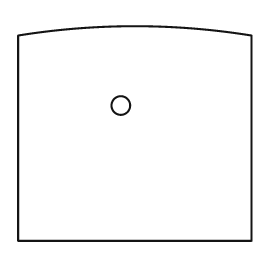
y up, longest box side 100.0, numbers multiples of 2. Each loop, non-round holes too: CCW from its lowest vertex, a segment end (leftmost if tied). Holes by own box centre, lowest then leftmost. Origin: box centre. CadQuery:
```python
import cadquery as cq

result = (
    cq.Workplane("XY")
    .moveTo(-50.0, -46.0)
    .lineTo(50.0, -46.0)
    .lineTo(50.0, 42.0)
    .threePointArc((0.0, 46.0), (-50.0, 42.0))
    .close()
    .moveTo(-6.0, 12.0)
    .circle(4.0)
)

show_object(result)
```